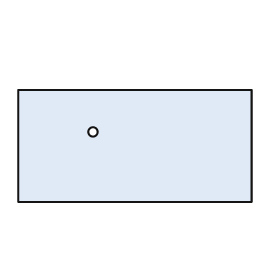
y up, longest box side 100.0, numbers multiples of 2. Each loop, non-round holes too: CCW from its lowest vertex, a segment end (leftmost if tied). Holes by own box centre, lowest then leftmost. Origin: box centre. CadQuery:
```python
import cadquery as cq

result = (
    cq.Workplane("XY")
    .moveTo(-50.0, -24.0)
    .lineTo(50.0, -24.0)
    .lineTo(50.0, 24.0)
    .lineTo(-50.0, 24.0)
    .close()
    .moveTo(-18.0, 6.0)
    .circle(2.0)
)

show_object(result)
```